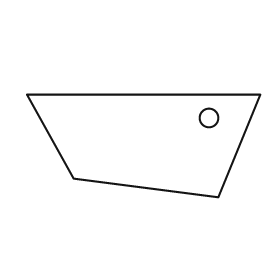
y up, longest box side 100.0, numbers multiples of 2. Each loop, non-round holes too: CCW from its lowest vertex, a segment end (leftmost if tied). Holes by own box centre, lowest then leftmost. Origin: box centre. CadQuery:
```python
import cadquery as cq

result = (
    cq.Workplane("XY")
    .moveTo(32.0, -22.0)
    .lineTo(50.0, 22.0)
    .lineTo(-50.0, 22.0)
    .lineTo(-30.0, -14.0)
    .close()
    .moveTo(28.0, 12.0)
    .circle(4.0)
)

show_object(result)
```